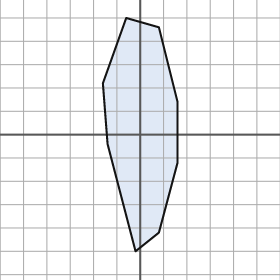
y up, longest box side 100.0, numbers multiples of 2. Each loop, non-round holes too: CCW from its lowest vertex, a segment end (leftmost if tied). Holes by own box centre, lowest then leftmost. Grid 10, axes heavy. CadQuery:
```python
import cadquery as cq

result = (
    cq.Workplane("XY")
    .moveTo(-2.0, -50.0)
    .lineTo(8.0, -42.0)
    .lineTo(16.0, -12.0)
    .lineTo(16.0, 14.0)
    .lineTo(8.0, 46.0)
    .lineTo(-6.0, 50.0)
    .lineTo(-16.0, 22.0)
    .lineTo(-14.0, -4.0)
    .close()
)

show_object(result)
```